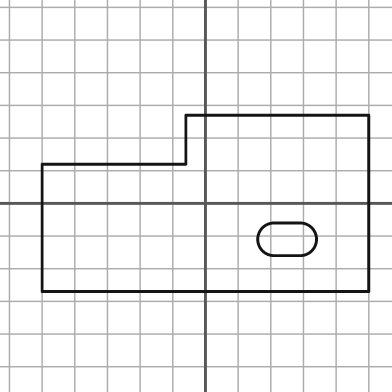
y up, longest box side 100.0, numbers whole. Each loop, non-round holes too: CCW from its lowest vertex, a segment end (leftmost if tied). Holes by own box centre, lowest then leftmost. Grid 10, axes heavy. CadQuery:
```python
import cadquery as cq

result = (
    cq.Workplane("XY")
    .moveTo(-50.0, -27.0)
    .lineTo(50.0, -27.0)
    .lineTo(50.0, 27.0)
    .lineTo(-6.0, 27.0)
    .lineTo(-6.0, 12.0)
    .lineTo(-50.0, 12.0)
    .close()
    .moveTo(21.0, -16.0)
    .lineTo(29.0, -16.0)
    .threePointArc((34.0, -11.0), (29.0, -6.0))
    .lineTo(21.0, -6.0)
    .threePointArc((16.0, -11.0), (21.0, -16.0))
    .close()
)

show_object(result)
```